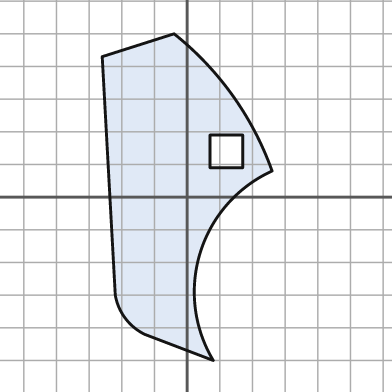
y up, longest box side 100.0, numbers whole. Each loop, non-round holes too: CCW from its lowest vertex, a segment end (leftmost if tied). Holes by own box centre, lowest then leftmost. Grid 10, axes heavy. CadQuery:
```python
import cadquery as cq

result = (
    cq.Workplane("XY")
    .moveTo(8.0, -50.0)
    .threePointArc((4.0, -17.0), (26.0, 8.0))
    .threePointArc((14.0, 31.0), (-4.0, 50.0))
    .lineTo(-26.0, 43.0)
    .lineTo(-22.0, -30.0)
    .threePointArc((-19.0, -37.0), (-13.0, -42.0))
    .close()
    .moveTo(7.0, 9.0)
    .lineTo(17.0, 9.0)
    .lineTo(17.0, 19.0)
    .lineTo(7.0, 19.0)
    .close()
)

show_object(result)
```